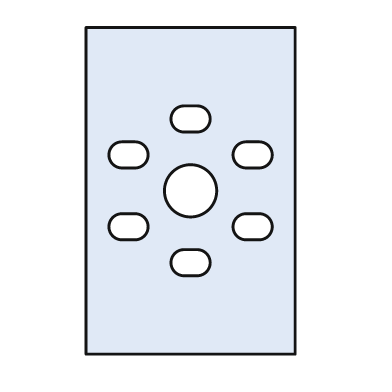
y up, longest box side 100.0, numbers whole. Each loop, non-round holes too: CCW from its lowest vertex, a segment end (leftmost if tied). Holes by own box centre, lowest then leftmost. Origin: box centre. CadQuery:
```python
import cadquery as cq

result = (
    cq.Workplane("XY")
    .moveTo(-32.0, -50.0)
    .lineTo(32.0, -50.0)
    .lineTo(32.0, 50.0)
    .lineTo(-32.0, 50.0)
    .close()
    .moveTo(-2.0, -26.0)
    .lineTo(2.0, -26.0)
    .threePointArc((6.0, -22.0), (2.0, -18.0))
    .lineTo(-2.0, -18.0)
    .threePointArc((-6.0, -22.0), (-2.0, -26.0))
    .close()
    .moveTo(-21.0, -15.0)
    .lineTo(-17.0, -15.0)
    .threePointArc((-13.0, -11.0), (-17.0, -7.0))
    .lineTo(-21.0, -7.0)
    .threePointArc((-25.0, -11.0), (-21.0, -15.0))
    .close()
    .moveTo(17.0, -15.0)
    .lineTo(21.0, -15.0)
    .threePointArc((25.0, -11.0), (21.0, -7.0))
    .lineTo(17.0, -7.0)
    .threePointArc((13.0, -11.0), (17.0, -15.0))
    .close()
    .moveTo(0.0, 0.0)
    .circle(8.0)
    .moveTo(-21.0, 7.0)
    .lineTo(-17.0, 7.0)
    .threePointArc((-13.0, 11.0), (-17.0, 15.0))
    .lineTo(-21.0, 15.0)
    .threePointArc((-25.0, 11.0), (-21.0, 7.0))
    .close()
    .moveTo(17.0, 7.0)
    .lineTo(21.0, 7.0)
    .threePointArc((25.0, 11.0), (21.0, 15.0))
    .lineTo(17.0, 15.0)
    .threePointArc((13.0, 11.0), (17.0, 7.0))
    .close()
    .moveTo(-2.0, 18.0)
    .lineTo(2.0, 18.0)
    .threePointArc((6.0, 22.0), (2.0, 26.0))
    .lineTo(-2.0, 26.0)
    .threePointArc((-6.0, 22.0), (-2.0, 18.0))
    .close()
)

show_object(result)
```